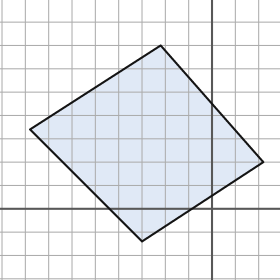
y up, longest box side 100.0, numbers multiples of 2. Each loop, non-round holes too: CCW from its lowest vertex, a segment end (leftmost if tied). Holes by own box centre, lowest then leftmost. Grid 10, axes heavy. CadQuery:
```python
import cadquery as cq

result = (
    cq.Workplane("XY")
    .moveTo(-30.0, -14.0)
    .lineTo(22.0, 20.0)
    .lineTo(-22.0, 70.0)
    .lineTo(-78.0, 34.0)
    .close()
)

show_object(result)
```